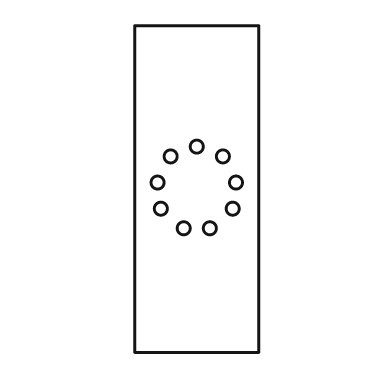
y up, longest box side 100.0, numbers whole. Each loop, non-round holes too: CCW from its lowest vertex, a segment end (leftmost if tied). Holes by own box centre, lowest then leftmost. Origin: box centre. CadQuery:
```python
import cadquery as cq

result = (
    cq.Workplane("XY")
    .moveTo(-19.0, -50.0)
    .lineTo(19.0, -50.0)
    .lineTo(19.0, 50.0)
    .lineTo(-19.0, 50.0)
    .close()
    .moveTo(-4.0, -12.0)
    .circle(2.0)
    .moveTo(4.0, -12.0)
    .circle(2.0)
    .moveTo(-11.0, -6.0)
    .circle(2.0)
    .moveTo(11.0, -6.0)
    .circle(2.0)
    .moveTo(-12.0, 2.0)
    .circle(2.0)
    .moveTo(12.0, 2.0)
    .circle(2.0)
    .moveTo(-8.0, 10.0)
    .circle(2.0)
    .moveTo(8.0, 10.0)
    .circle(2.0)
    .moveTo(0.0, 13.0)
    .circle(2.0)
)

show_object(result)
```